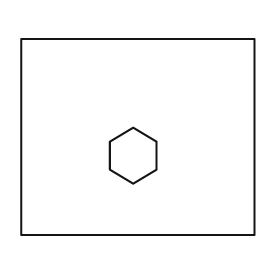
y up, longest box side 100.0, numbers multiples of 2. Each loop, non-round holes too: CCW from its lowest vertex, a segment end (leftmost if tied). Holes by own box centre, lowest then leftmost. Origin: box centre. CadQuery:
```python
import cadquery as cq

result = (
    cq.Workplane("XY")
    .moveTo(-50.0, -42.0)
    .lineTo(50.0, -42.0)
    .lineTo(50.0, 42.0)
    .lineTo(-50.0, 42.0)
    .close()
    .moveTo(-2.0, -20.0)
    .lineTo(8.0, -14.0)
    .lineTo(8.0, -2.0)
    .lineTo(-2.0, 4.0)
    .lineTo(-12.0, -2.0)
    .lineTo(-12.0, -14.0)
    .close()
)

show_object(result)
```